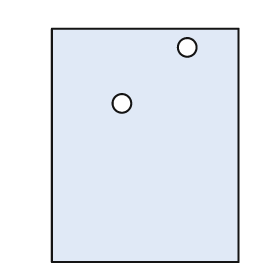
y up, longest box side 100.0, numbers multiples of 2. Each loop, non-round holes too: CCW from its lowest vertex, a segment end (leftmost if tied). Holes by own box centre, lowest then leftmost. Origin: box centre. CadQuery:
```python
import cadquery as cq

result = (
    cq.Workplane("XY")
    .moveTo(-40.0, -50.0)
    .lineTo(40.0, -50.0)
    .lineTo(40.0, 50.0)
    .lineTo(-40.0, 50.0)
    .close()
    .moveTo(-10.0, 18.0)
    .circle(4.0)
    .moveTo(18.0, 42.0)
    .circle(4.0)
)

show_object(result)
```